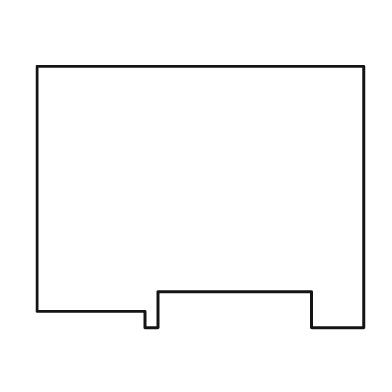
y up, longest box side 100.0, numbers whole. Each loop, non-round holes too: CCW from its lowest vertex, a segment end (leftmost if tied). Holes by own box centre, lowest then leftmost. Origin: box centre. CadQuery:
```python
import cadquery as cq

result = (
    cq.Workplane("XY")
    .moveTo(-17.0, -40.0)
    .lineTo(-13.0, -40.0)
    .lineTo(-13.0, -29.0)
    .lineTo(34.0, -29.0)
    .lineTo(34.0, -40.0)
    .lineTo(50.0, -40.0)
    .lineTo(50.0, 40.0)
    .lineTo(-50.0, 40.0)
    .lineTo(-50.0, -35.0)
    .lineTo(-17.0, -35.0)
    .close()
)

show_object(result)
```